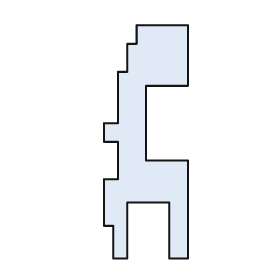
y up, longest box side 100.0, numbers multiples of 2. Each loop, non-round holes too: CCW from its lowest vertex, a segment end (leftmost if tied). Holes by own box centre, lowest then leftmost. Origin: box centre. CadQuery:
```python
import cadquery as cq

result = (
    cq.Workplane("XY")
    .moveTo(-14.0, -50.0)
    .lineTo(-8.0, -50.0)
    .lineTo(-8.0, -26.0)
    .lineTo(10.0, -26.0)
    .lineTo(10.0, -50.0)
    .lineTo(18.0, -50.0)
    .lineTo(18.0, -8.0)
    .lineTo(0.0, -8.0)
    .lineTo(0.0, 24.0)
    .lineTo(18.0, 24.0)
    .lineTo(18.0, 50.0)
    .lineTo(-4.0, 50.0)
    .lineTo(-4.0, 42.0)
    .lineTo(-8.0, 42.0)
    .lineTo(-8.0, 30.0)
    .lineTo(-12.0, 30.0)
    .lineTo(-12.0, 8.0)
    .lineTo(-18.0, 8.0)
    .lineTo(-18.0, 0.0)
    .lineTo(-12.0, 0.0)
    .lineTo(-12.0, -16.0)
    .lineTo(-18.0, -16.0)
    .lineTo(-18.0, -36.0)
    .lineTo(-14.0, -36.0)
    .close()
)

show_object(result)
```